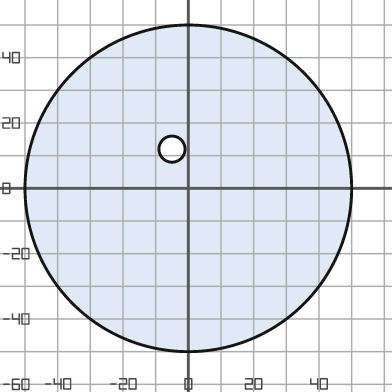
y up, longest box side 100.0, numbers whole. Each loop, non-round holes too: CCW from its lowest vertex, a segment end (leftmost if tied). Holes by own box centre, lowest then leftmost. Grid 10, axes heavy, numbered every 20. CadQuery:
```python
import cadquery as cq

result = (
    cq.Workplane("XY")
    .moveTo(0.0, 0.0)
    .circle(50.0)
    .moveTo(-5.0, 12.0)
    .circle(4.0)
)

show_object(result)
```